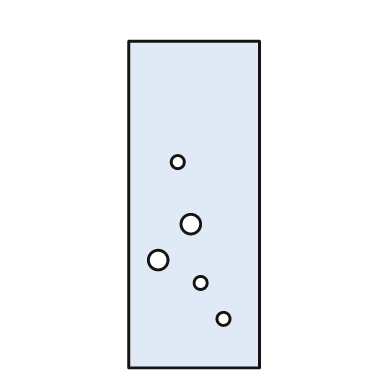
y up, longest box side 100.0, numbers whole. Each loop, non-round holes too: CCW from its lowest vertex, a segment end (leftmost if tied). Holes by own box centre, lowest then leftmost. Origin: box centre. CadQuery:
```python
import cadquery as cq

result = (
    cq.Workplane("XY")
    .moveTo(-20.0, -50.0)
    .lineTo(20.0, -50.0)
    .lineTo(20.0, 50.0)
    .lineTo(-20.0, 50.0)
    .close()
    .moveTo(9.0, -35.0)
    .circle(2.0)
    .moveTo(2.0, -24.0)
    .circle(2.0)
    .moveTo(-11.0, -17.0)
    .circle(3.0)
    .moveTo(-1.0, -6.0)
    .circle(3.0)
    .moveTo(-5.0, 13.0)
    .circle(2.0)
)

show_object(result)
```